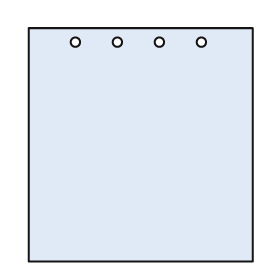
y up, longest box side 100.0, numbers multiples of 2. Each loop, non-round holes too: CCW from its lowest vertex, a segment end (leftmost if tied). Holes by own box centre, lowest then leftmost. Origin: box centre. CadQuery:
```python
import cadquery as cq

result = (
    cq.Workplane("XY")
    .moveTo(-48.0, -50.0)
    .lineTo(48.0, -50.0)
    .lineTo(48.0, 50.0)
    .lineTo(-48.0, 50.0)
    .close()
    .moveTo(-28.0, 44.0)
    .circle(2.0)
    .moveTo(-10.0, 44.0)
    .circle(2.0)
    .moveTo(8.0, 44.0)
    .circle(2.0)
    .moveTo(26.0, 44.0)
    .circle(2.0)
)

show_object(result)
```